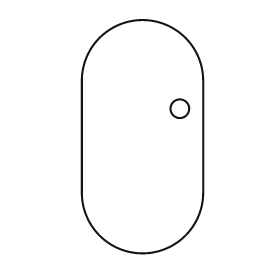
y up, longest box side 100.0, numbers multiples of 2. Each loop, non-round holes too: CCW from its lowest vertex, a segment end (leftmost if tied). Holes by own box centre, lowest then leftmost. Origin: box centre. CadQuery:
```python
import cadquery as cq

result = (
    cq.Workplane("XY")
    .moveTo(-26.0, -24.0)
    .threePointArc((0.0, -50.0), (26.0, -24.0))
    .lineTo(26.0, 24.0)
    .threePointArc((0.0, 50.0), (-26.0, 24.0))
    .close()
    .moveTo(16.0, 12.0)
    .circle(4.0)
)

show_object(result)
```